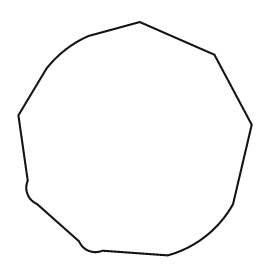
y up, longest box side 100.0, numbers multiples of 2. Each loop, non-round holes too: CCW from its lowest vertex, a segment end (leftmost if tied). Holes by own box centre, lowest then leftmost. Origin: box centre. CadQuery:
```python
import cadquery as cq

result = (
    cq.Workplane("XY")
    .moveTo(14.0, -50.0)
    .threePointArc((30.0, -42.0), (42.0, -28.0))
    .lineTo(50.0, 6.0)
    .lineTo(34.0, 36.0)
    .lineTo(2.0, 50.0)
    .lineTo(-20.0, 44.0)
    .threePointArc((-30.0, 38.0), (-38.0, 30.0))
    .lineTo(-50.0, 10.0)
    .lineTo(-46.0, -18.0)
    .threePointArc((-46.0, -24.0), (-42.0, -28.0))
    .lineTo(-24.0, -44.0)
    .threePointArc((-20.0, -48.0), (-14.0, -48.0))
    .close()
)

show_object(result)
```